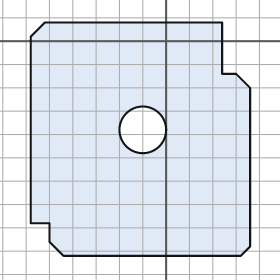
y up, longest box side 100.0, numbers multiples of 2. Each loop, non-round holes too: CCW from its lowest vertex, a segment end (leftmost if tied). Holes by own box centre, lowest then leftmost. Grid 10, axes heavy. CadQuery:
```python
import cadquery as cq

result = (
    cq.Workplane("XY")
    .moveTo(-44.0, -92.0)
    .lineTo(32.0, -92.0)
    .lineTo(36.0, -88.0)
    .lineTo(36.0, -20.0)
    .lineTo(30.0, -14.0)
    .lineTo(24.0, -14.0)
    .lineTo(24.0, 8.0)
    .lineTo(-52.0, 8.0)
    .lineTo(-58.0, 2.0)
    .lineTo(-58.0, -78.0)
    .lineTo(-50.0, -78.0)
    .lineTo(-50.0, -86.0)
    .close()
    .moveTo(-10.0, -38.0)
    .circle(10.0)
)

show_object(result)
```